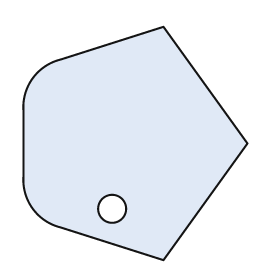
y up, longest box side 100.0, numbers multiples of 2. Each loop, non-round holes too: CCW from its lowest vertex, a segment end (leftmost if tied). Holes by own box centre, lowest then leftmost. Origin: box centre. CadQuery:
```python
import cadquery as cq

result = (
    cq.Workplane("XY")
    .moveTo(12.0, -50.0)
    .lineTo(48.0, 0.0)
    .lineTo(12.0, 50.0)
    .lineTo(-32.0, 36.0)
    .threePointArc((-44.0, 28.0), (-48.0, 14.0))
    .lineTo(-48.0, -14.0)
    .threePointArc((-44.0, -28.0), (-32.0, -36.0))
    .close()
    .moveTo(-10.0, -28.0)
    .circle(6.0)
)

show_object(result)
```